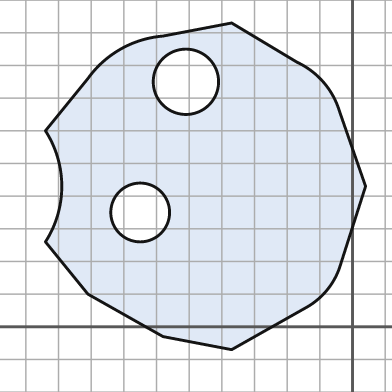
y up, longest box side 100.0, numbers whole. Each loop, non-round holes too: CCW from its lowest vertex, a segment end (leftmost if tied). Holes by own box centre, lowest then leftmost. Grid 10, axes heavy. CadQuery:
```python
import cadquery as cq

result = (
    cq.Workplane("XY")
    .moveTo(-37.0, -7.0)
    .lineTo(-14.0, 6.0)
    .threePointArc((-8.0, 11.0), (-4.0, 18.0))
    .lineTo(4.0, 43.0)
    .lineTo(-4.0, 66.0)
    .threePointArc((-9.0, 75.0), (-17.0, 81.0))
    .lineTo(-37.0, 93.0)
    .lineTo(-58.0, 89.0)
    .threePointArc((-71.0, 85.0), (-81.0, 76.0))
    .lineTo(-94.0, 60.0)
    .threePointArc((-89.0, 43.0), (-94.0, 26.0))
    .lineTo(-81.0, 10.0)
    .lineTo(-58.0, -3.0)
    .close()
    .moveTo(-65.0, 35.0)
    .circle(9.0)
    .moveTo(-51.0, 75.0)
    .circle(10.0)
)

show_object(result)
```